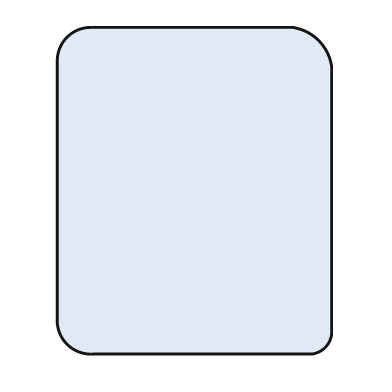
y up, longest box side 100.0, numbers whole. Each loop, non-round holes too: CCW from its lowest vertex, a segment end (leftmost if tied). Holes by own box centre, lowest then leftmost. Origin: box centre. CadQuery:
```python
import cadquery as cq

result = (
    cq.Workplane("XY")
    .moveTo(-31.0, -50.0)
    .lineTo(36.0, -50.0)
    .threePointArc((40.0, -48.0), (42.0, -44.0))
    .lineTo(42.0, 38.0)
    .threePointArc((38.0, 46.0), (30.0, 50.0))
    .lineTo(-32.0, 50.0)
    .threePointArc((-39.0, 47.0), (-42.0, 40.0))
    .lineTo(-42.0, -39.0)
    .threePointArc((-39.0, -47.0), (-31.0, -50.0))
    .close()
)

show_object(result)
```